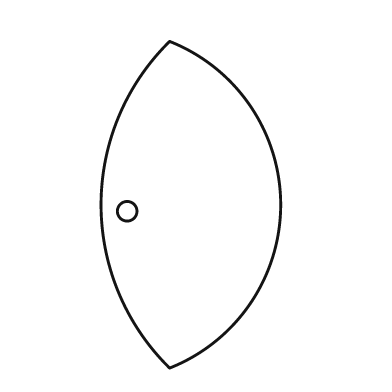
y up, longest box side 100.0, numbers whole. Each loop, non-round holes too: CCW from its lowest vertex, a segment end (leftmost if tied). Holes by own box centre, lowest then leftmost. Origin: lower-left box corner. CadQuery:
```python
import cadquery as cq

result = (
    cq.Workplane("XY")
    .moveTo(21.0, 0.0)
    .threePointArc((55.0, 50.0), (21.0, 100.0))
    .threePointArc((0.0, 50.0), (21.0, 0.0))
    .close()
    .moveTo(8.0, 48.0)
    .circle(3.0)
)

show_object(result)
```